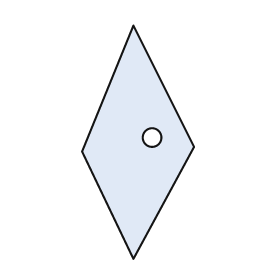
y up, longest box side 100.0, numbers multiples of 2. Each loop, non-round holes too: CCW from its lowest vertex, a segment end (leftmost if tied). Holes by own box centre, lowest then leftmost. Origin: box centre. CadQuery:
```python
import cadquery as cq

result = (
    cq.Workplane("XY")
    .moveTo(-2.0, -50.0)
    .lineTo(24.0, -2.0)
    .lineTo(-2.0, 50.0)
    .lineTo(-24.0, -4.0)
    .close()
    .moveTo(6.0, 2.0)
    .circle(4.0)
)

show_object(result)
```